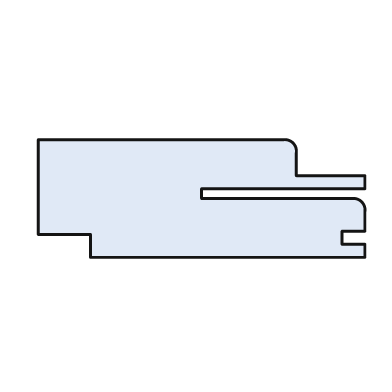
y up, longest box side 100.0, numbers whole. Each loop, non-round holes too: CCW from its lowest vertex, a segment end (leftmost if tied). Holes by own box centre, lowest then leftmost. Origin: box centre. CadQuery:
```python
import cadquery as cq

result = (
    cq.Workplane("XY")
    .moveTo(-34.0, -18.0)
    .lineTo(50.0, -18.0)
    .lineTo(50.0, -14.0)
    .lineTo(43.0, -14.0)
    .lineTo(43.0, -10.0)
    .lineTo(50.0, -10.0)
    .lineTo(50.0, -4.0)
    .threePointArc((49.0, -1.0), (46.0, 0.0))
    .lineTo(0.0, 0.0)
    .lineTo(0.0, 3.0)
    .lineTo(50.0, 3.0)
    .lineTo(50.0, 7.0)
    .lineTo(29.0, 7.0)
    .lineTo(29.0, 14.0)
    .threePointArc((28.0, 17.0), (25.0, 18.0))
    .lineTo(-50.0, 18.0)
    .lineTo(-50.0, -11.0)
    .lineTo(-34.0, -11.0)
    .close()
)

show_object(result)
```